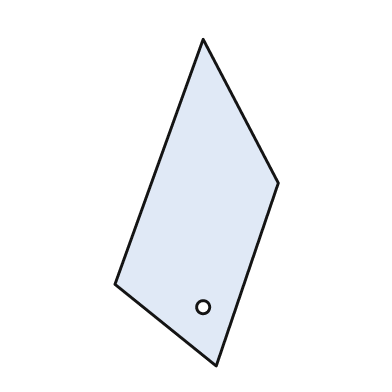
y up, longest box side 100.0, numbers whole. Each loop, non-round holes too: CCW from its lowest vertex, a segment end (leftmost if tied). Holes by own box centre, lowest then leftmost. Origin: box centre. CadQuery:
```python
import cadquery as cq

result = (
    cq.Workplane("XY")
    .moveTo(6.0, -50.0)
    .lineTo(25.0, 6.0)
    .lineTo(2.0, 50.0)
    .lineTo(-25.0, -25.0)
    .close()
    .moveTo(2.0, -32.0)
    .circle(2.0)
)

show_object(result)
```